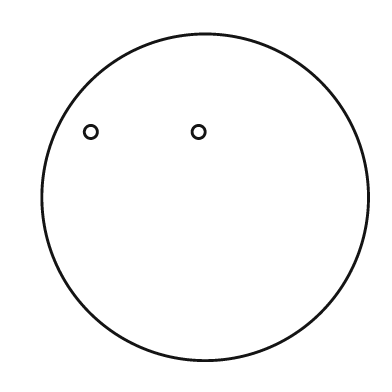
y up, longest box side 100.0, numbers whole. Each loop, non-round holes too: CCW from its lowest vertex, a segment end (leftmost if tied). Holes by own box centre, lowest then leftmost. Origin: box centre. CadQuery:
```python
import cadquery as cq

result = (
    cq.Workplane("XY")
    .moveTo(0.0, 0.0)
    .circle(50.0)
    .moveTo(-35.0, 20.0)
    .circle(2.0)
    .moveTo(-2.0, 20.0)
    .circle(2.0)
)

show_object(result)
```